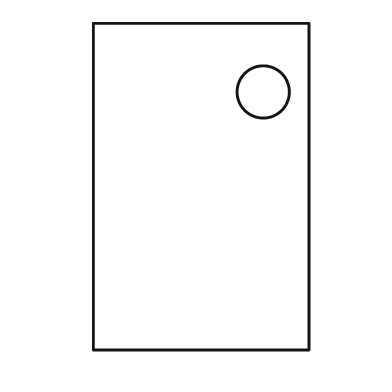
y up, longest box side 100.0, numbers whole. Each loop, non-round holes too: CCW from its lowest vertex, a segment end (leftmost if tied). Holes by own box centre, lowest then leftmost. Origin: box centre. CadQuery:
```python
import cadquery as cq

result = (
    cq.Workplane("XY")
    .moveTo(-33.0, -50.0)
    .lineTo(33.0, -50.0)
    .lineTo(33.0, 50.0)
    .lineTo(-33.0, 50.0)
    .close()
    .moveTo(19.0, 29.0)
    .circle(8.0)
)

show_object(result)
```